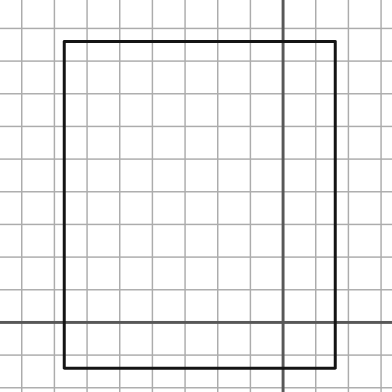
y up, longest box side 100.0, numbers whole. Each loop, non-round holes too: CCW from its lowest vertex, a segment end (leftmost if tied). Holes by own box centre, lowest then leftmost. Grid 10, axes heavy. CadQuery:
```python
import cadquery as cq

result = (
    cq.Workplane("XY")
    .moveTo(-67.0, -14.0)
    .lineTo(16.0, -14.0)
    .lineTo(16.0, 86.0)
    .lineTo(-67.0, 86.0)
    .close()
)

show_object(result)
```